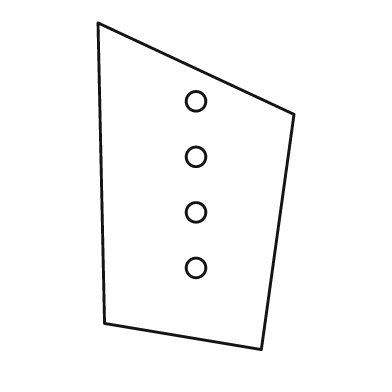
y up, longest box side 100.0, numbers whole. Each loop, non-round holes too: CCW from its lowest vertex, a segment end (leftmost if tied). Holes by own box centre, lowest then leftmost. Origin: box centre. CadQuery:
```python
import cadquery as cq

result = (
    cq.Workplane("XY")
    .moveTo(20.0, -50.0)
    .lineTo(30.0, 22.0)
    .lineTo(-30.0, 50.0)
    .lineTo(-28.0, -42.0)
    .close()
    .moveTo(0.0, -25.0)
    .circle(3.0)
    .moveTo(0.0, -8.0)
    .circle(3.0)
    .moveTo(0.0, 9.0)
    .circle(3.0)
    .moveTo(0.0, 26.0)
    .circle(3.0)
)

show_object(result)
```